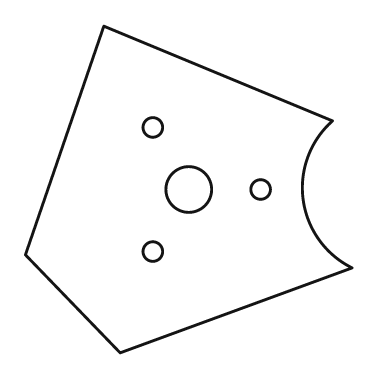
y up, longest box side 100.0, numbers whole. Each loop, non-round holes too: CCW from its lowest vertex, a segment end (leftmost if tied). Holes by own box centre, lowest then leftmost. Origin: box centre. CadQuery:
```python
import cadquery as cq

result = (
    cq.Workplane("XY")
    .moveTo(-21.0, -50.0)
    .lineTo(50.0, -24.0)
    .threePointArc((35.0, -3.0), (44.0, 21.0))
    .lineTo(-26.0, 50.0)
    .lineTo(-50.0, -20.0)
    .close()
    .moveTo(-11.0, -19.0)
    .circle(3.0)
    .moveTo(0.0, 0.0)
    .circle(7.0)
    .moveTo(22.0, 0.0)
    .circle(3.0)
    .moveTo(-11.0, 19.0)
    .circle(3.0)
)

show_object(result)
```